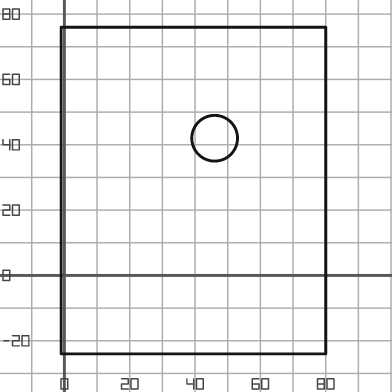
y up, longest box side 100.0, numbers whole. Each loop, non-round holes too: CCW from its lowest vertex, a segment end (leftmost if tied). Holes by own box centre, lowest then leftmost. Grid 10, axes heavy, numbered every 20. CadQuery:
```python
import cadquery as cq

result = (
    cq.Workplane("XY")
    .moveTo(-1.0, -24.0)
    .lineTo(80.0, -24.0)
    .lineTo(80.0, 76.0)
    .lineTo(-1.0, 76.0)
    .close()
    .moveTo(46.0, 42.0)
    .circle(7.0)
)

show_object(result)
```